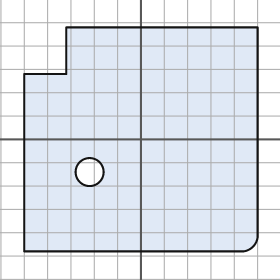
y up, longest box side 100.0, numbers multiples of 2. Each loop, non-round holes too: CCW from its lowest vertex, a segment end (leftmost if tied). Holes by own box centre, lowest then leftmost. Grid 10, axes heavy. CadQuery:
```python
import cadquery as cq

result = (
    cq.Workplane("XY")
    .moveTo(-50.0, -48.0)
    .lineTo(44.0, -48.0)
    .threePointArc((48.0, -46.0), (50.0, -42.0))
    .lineTo(50.0, 48.0)
    .lineTo(-32.0, 48.0)
    .lineTo(-32.0, 28.0)
    .lineTo(-50.0, 28.0)
    .close()
    .moveTo(-22.0, -14.0)
    .circle(6.0)
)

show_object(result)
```